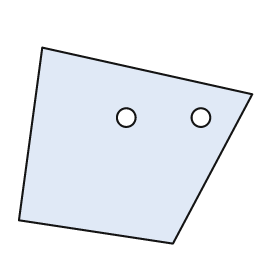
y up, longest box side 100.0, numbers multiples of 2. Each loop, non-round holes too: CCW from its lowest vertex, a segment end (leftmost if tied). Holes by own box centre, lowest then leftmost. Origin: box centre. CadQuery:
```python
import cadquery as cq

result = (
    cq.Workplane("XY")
    .moveTo(16.0, -42.0)
    .lineTo(50.0, 22.0)
    .lineTo(-40.0, 42.0)
    .lineTo(-50.0, -32.0)
    .close()
    .moveTo(-4.0, 12.0)
    .circle(4.0)
    .moveTo(28.0, 12.0)
    .circle(4.0)
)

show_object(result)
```